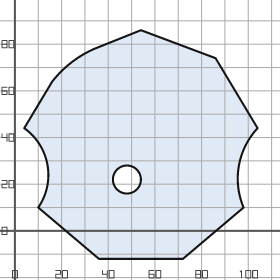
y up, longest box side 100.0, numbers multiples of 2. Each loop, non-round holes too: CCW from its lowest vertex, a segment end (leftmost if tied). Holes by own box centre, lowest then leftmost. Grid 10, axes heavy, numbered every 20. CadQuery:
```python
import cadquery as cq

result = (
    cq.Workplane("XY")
    .moveTo(36.0, -12.0)
    .lineTo(72.0, -12.0)
    .lineTo(98.0, 10.0)
    .threePointArc((96.0, 28.0), (104.0, 44.0))
    .lineTo(86.0, 74.0)
    .lineTo(54.0, 86.0)
    .lineTo(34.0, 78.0)
    .threePointArc((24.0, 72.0), (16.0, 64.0))
    .lineTo(4.0, 44.0)
    .threePointArc((14.0, 28.0), (10.0, 10.0))
    .close()
    .moveTo(48.0, 22.0)
    .circle(6.0)
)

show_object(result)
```